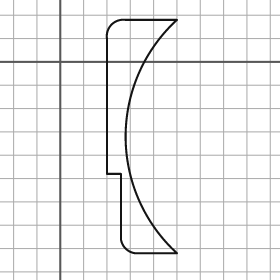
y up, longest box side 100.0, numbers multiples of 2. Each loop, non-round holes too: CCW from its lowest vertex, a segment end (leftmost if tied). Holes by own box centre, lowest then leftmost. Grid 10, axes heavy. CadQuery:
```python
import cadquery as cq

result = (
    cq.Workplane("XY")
    .moveTo(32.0, -82.0)
    .lineTo(50.0, -82.0)
    .threePointArc((28.0, -32.0), (50.0, 18.0))
    .lineTo(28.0, 18.0)
    .threePointArc((22.0, 16.0), (20.0, 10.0))
    .lineTo(20.0, -48.0)
    .lineTo(26.0, -48.0)
    .lineTo(26.0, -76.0)
    .threePointArc((28.0, -80.0), (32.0, -82.0))
    .close()
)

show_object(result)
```